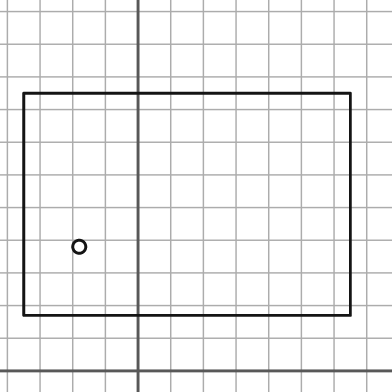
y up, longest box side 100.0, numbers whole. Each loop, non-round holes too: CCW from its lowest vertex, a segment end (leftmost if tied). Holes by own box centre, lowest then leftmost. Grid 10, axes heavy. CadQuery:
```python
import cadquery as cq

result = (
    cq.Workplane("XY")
    .moveTo(-35.0, 17.0)
    .lineTo(65.0, 17.0)
    .lineTo(65.0, 85.0)
    .lineTo(-35.0, 85.0)
    .close()
    .moveTo(-18.0, 38.0)
    .circle(2.0)
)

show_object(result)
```